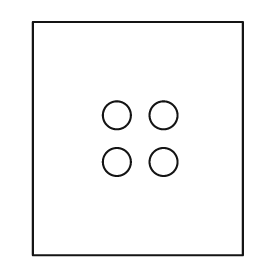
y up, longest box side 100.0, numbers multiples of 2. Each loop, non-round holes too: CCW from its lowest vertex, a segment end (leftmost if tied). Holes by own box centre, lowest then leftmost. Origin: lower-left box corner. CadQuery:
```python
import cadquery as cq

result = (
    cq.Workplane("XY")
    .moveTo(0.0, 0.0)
    .lineTo(90.0, 0.0)
    .lineTo(90.0, 100.0)
    .lineTo(0.0, 100.0)
    .close()
    .moveTo(36.0, 40.0)
    .circle(6.0)
    .moveTo(56.0, 40.0)
    .circle(6.0)
    .moveTo(36.0, 60.0)
    .circle(6.0)
    .moveTo(56.0, 60.0)
    .circle(6.0)
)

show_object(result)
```